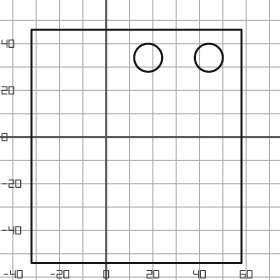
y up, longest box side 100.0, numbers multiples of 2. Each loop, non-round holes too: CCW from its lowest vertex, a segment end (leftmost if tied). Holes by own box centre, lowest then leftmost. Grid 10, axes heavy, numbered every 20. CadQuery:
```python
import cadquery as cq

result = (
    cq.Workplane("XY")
    .moveTo(-32.0, -54.0)
    .lineTo(58.0, -54.0)
    .lineTo(58.0, 46.0)
    .lineTo(-32.0, 46.0)
    .close()
    .moveTo(18.0, 34.0)
    .circle(6.0)
    .moveTo(44.0, 34.0)
    .circle(6.0)
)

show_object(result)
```